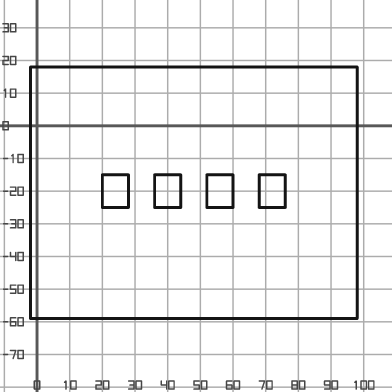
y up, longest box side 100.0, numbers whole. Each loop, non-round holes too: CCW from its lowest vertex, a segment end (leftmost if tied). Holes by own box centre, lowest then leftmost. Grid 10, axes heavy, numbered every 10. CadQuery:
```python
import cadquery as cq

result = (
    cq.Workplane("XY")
    .moveTo(-2.0, -59.0)
    .lineTo(98.0, -59.0)
    .lineTo(98.0, 18.0)
    .lineTo(-2.0, 18.0)
    .close()
    .moveTo(20.0, -25.0)
    .lineTo(28.0, -25.0)
    .lineTo(28.0, -15.0)
    .lineTo(20.0, -15.0)
    .close()
    .moveTo(36.0, -25.0)
    .lineTo(44.0, -25.0)
    .lineTo(44.0, -15.0)
    .lineTo(36.0, -15.0)
    .close()
    .moveTo(52.0, -25.0)
    .lineTo(60.0, -25.0)
    .lineTo(60.0, -15.0)
    .lineTo(52.0, -15.0)
    .close()
    .moveTo(68.0, -25.0)
    .lineTo(76.0, -25.0)
    .lineTo(76.0, -15.0)
    .lineTo(68.0, -15.0)
    .close()
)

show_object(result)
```